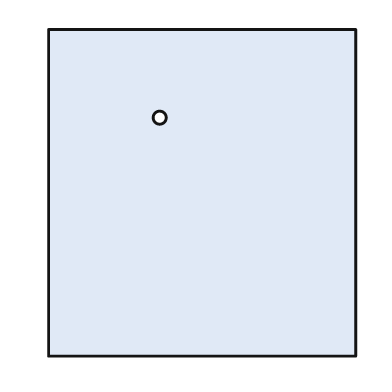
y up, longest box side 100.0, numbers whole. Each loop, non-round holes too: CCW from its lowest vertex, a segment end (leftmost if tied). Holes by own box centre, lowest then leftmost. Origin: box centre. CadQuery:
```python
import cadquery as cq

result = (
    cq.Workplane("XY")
    .moveTo(-47.0, -50.0)
    .lineTo(47.0, -50.0)
    .lineTo(47.0, 50.0)
    .lineTo(-47.0, 50.0)
    .close()
    .moveTo(-13.0, 23.0)
    .circle(2.0)
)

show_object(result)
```